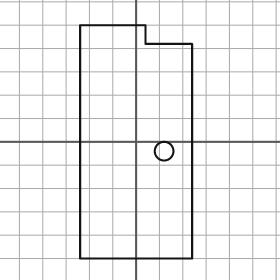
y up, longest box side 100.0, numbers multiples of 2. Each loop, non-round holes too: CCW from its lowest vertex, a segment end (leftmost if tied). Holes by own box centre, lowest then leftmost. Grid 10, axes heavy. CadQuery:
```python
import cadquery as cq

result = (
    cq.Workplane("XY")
    .moveTo(-24.0, -50.0)
    .lineTo(24.0, -50.0)
    .lineTo(24.0, 42.0)
    .lineTo(4.0, 42.0)
    .lineTo(4.0, 50.0)
    .lineTo(-24.0, 50.0)
    .close()
    .moveTo(12.0, -4.0)
    .circle(4.0)
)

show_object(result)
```